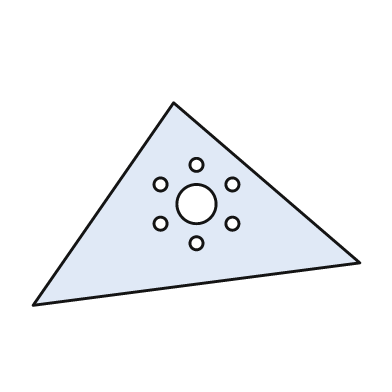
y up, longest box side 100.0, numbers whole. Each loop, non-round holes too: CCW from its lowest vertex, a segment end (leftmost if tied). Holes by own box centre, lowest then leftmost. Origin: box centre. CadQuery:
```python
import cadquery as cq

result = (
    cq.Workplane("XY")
    .moveTo(-50.0, -31.0)
    .lineTo(50.0, -18.0)
    .lineTo(-7.0, 31.0)
    .close()
    .moveTo(0.0, -12.0)
    .circle(2.0)
    .moveTo(-11.0, -6.0)
    .circle(2.0)
    .moveTo(11.0, -6.0)
    .circle(2.0)
    .moveTo(0.0, 0.0)
    .circle(6.0)
    .moveTo(-11.0, 6.0)
    .circle(2.0)
    .moveTo(11.0, 6.0)
    .circle(2.0)
    .moveTo(0.0, 12.0)
    .circle(2.0)
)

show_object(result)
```